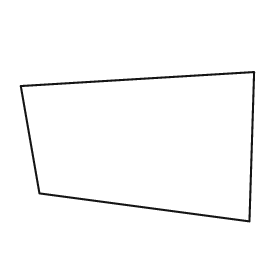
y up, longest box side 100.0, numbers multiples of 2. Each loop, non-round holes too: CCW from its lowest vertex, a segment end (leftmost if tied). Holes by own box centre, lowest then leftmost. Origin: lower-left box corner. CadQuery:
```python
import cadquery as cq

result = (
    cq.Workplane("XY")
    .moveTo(98.0, 0.0)
    .lineTo(100.0, 64.0)
    .lineTo(0.0, 58.0)
    .lineTo(8.0, 12.0)
    .close()
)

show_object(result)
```